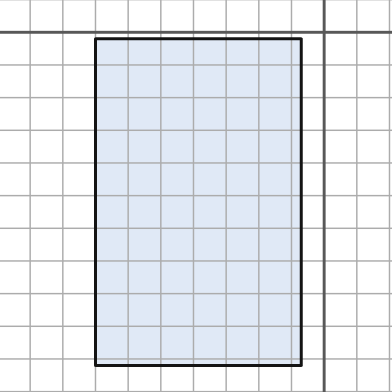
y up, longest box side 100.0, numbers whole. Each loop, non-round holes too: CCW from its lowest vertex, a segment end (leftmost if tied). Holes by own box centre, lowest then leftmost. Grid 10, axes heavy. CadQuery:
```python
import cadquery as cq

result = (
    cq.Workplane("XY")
    .moveTo(-70.0, -102.0)
    .lineTo(-7.0, -102.0)
    .lineTo(-7.0, -2.0)
    .lineTo(-70.0, -2.0)
    .close()
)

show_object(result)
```